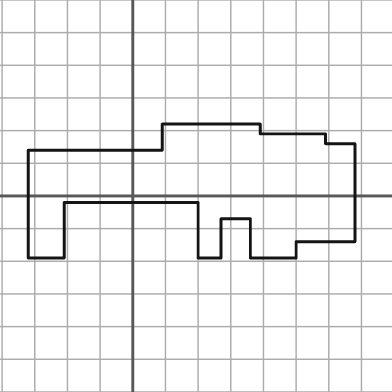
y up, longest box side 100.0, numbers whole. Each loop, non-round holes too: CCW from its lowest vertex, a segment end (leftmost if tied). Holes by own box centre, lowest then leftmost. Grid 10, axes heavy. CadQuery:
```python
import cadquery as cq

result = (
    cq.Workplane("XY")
    .moveTo(-32.0, -19.0)
    .lineTo(-21.0, -19.0)
    .lineTo(-21.0, -2.0)
    .lineTo(20.0, -2.0)
    .lineTo(20.0, -19.0)
    .lineTo(27.0, -19.0)
    .lineTo(27.0, -7.0)
    .lineTo(36.0, -7.0)
    .lineTo(36.0, -19.0)
    .lineTo(50.0, -19.0)
    .lineTo(50.0, -14.0)
    .lineTo(68.0, -14.0)
    .lineTo(68.0, 16.0)
    .lineTo(59.0, 16.0)
    .lineTo(59.0, 19.0)
    .lineTo(39.0, 19.0)
    .lineTo(39.0, 22.0)
    .lineTo(9.0, 22.0)
    .lineTo(9.0, 14.0)
    .lineTo(-32.0, 14.0)
    .close()
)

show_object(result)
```